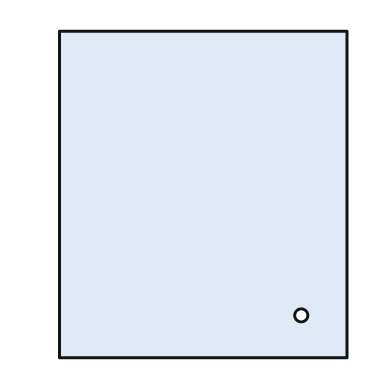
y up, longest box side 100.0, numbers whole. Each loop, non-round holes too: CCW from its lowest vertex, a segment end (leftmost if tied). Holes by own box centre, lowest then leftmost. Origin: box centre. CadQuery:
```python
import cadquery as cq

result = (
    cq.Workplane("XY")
    .moveTo(-44.0, -50.0)
    .lineTo(44.0, -50.0)
    .lineTo(44.0, 50.0)
    .lineTo(-44.0, 50.0)
    .close()
    .moveTo(30.0, -37.0)
    .circle(2.0)
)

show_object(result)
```